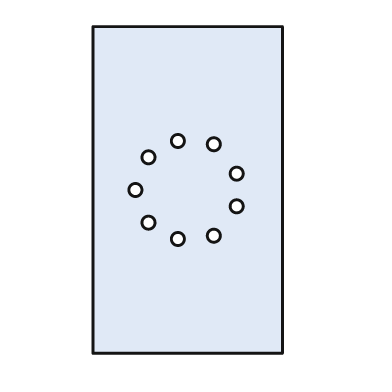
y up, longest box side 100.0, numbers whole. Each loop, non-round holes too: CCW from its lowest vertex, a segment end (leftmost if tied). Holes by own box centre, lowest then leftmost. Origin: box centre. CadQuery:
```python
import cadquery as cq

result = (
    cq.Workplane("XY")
    .moveTo(-29.0, -50.0)
    .lineTo(29.0, -50.0)
    .lineTo(29.0, 50.0)
    .lineTo(-29.0, 50.0)
    .close()
    .moveTo(-3.0, -15.0)
    .circle(2.0)
    .moveTo(8.0, -14.0)
    .circle(2.0)
    .moveTo(-12.0, -10.0)
    .circle(2.0)
    .moveTo(15.0, -5.0)
    .circle(2.0)
    .moveTo(-16.0, 0.0)
    .circle(2.0)
    .moveTo(15.0, 5.0)
    .circle(2.0)
    .moveTo(-12.0, 10.0)
    .circle(2.0)
    .moveTo(8.0, 14.0)
    .circle(2.0)
    .moveTo(-3.0, 15.0)
    .circle(2.0)
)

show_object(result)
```